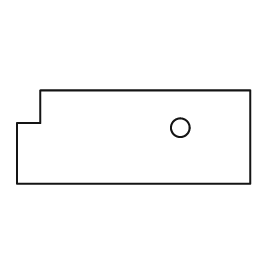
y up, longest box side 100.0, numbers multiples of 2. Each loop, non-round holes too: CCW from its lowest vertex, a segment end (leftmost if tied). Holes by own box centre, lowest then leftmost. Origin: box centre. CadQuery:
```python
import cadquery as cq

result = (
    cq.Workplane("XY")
    .moveTo(-50.0, -20.0)
    .lineTo(50.0, -20.0)
    .lineTo(50.0, 20.0)
    .lineTo(-40.0, 20.0)
    .lineTo(-40.0, 6.0)
    .lineTo(-50.0, 6.0)
    .close()
    .moveTo(20.0, 4.0)
    .circle(4.0)
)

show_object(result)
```